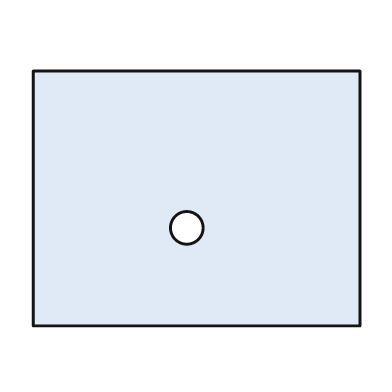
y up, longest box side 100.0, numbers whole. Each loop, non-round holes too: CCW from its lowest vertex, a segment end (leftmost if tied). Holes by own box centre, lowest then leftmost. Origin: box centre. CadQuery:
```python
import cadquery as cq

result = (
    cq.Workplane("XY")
    .moveTo(-50.0, -39.0)
    .lineTo(50.0, -39.0)
    .lineTo(50.0, 39.0)
    .lineTo(-50.0, 39.0)
    .close()
    .moveTo(-3.0, -9.0)
    .circle(5.0)
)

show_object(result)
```